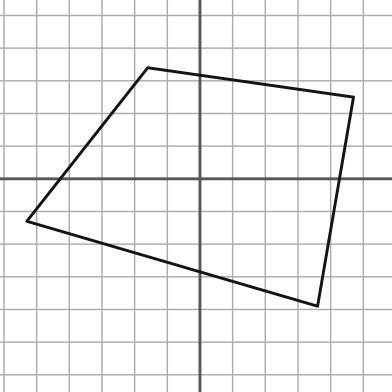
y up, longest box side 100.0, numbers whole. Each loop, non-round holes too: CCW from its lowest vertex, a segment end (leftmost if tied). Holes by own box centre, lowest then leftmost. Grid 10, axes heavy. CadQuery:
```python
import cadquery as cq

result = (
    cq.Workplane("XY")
    .moveTo(36.0, -39.0)
    .lineTo(47.0, 25.0)
    .lineTo(-16.0, 34.0)
    .lineTo(-53.0, -13.0)
    .close()
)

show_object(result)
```